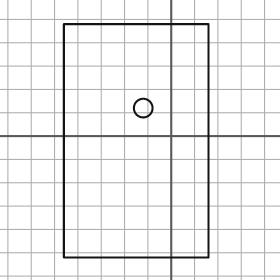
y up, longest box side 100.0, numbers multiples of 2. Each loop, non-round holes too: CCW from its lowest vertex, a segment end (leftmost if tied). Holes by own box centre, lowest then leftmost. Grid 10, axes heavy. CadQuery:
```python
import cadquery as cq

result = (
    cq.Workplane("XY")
    .moveTo(-46.0, -52.0)
    .lineTo(16.0, -52.0)
    .lineTo(16.0, 48.0)
    .lineTo(-46.0, 48.0)
    .close()
    .moveTo(-12.0, 12.0)
    .circle(4.0)
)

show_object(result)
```